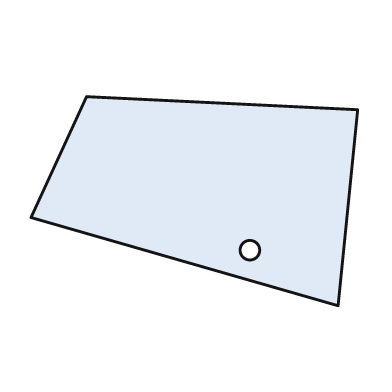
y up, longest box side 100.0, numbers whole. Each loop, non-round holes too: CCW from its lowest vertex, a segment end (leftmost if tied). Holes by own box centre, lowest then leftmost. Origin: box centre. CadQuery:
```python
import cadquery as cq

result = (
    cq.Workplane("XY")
    .moveTo(44.0, -32.0)
    .lineTo(50.0, 28.0)
    .lineTo(-33.0, 32.0)
    .lineTo(-50.0, -5.0)
    .close()
    .moveTo(17.0, -15.0)
    .circle(3.0)
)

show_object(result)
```